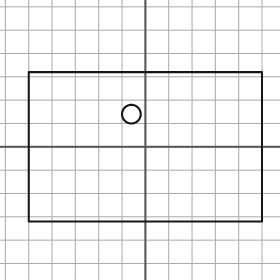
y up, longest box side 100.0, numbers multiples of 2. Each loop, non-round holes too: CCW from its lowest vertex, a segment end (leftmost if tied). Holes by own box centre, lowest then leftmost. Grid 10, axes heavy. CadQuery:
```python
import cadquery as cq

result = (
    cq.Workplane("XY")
    .moveTo(-50.0, -32.0)
    .lineTo(50.0, -32.0)
    .lineTo(50.0, 32.0)
    .lineTo(-50.0, 32.0)
    .close()
    .moveTo(-6.0, 14.0)
    .circle(4.0)
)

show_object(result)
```